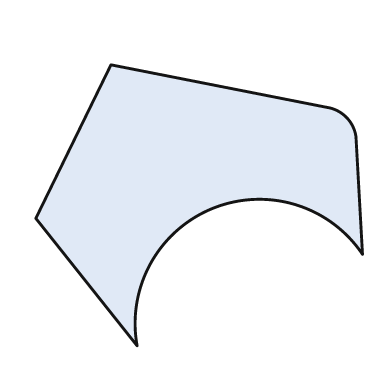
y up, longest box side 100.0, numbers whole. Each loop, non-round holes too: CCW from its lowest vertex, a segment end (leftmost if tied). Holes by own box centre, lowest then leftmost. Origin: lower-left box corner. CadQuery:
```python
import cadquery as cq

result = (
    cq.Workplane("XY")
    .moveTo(31.0, 0.0)
    .threePointArc((54.0, 42.0), (100.0, 28.0))
    .lineTo(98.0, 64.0)
    .threePointArc((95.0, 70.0), (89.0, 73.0))
    .lineTo(23.0, 86.0)
    .lineTo(0.0, 39.0)
    .close()
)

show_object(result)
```